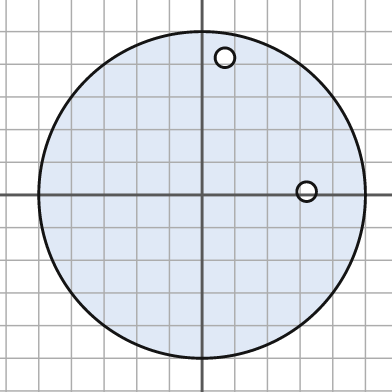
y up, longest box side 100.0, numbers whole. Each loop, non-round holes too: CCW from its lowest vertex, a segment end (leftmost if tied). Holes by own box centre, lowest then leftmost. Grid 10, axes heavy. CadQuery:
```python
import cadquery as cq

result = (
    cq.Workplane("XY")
    .moveTo(0.0, 0.0)
    .circle(50.0)
    .moveTo(32.0, 1.0)
    .circle(3.0)
    .moveTo(7.0, 42.0)
    .circle(3.0)
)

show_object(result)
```